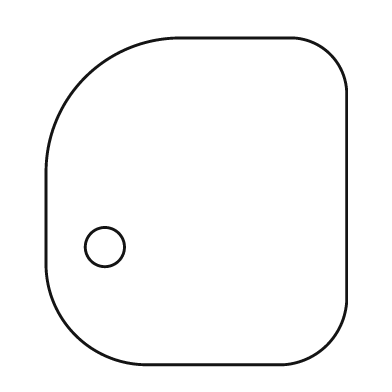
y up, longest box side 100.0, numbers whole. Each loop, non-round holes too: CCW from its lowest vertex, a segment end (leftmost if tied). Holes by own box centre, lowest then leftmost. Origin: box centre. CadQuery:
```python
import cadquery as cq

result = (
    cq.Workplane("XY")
    .moveTo(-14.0, -50.0)
    .lineTo(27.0, -50.0)
    .threePointArc((40.0, -44.0), (46.0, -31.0))
    .lineTo(46.0, 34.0)
    .threePointArc((41.0, 45.0), (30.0, 50.0))
    .lineTo(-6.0, 50.0)
    .threePointArc((-34.0, 38.0), (-46.0, 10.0))
    .lineTo(-46.0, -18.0)
    .threePointArc((-37.0, -41.0), (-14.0, -50.0))
    .close()
    .moveTo(-28.0, -14.0)
    .circle(6.0)
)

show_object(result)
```